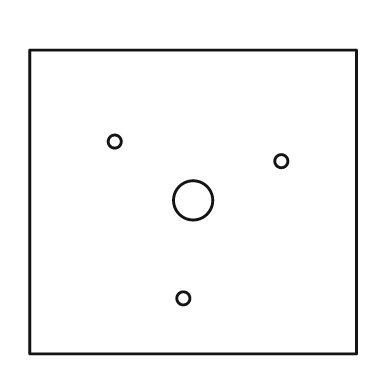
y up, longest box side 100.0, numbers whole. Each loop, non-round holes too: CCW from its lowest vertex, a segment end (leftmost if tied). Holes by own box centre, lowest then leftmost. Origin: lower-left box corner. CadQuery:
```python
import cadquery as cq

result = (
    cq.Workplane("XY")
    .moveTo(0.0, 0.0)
    .lineTo(100.0, 0.0)
    .lineTo(100.0, 93.0)
    .lineTo(0.0, 93.0)
    .close()
    .moveTo(47.0, 17.0)
    .circle(2.0)
    .moveTo(50.0, 47.0)
    .circle(6.0)
    .moveTo(77.0, 59.0)
    .circle(2.0)
    .moveTo(26.0, 65.0)
    .circle(2.0)
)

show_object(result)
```